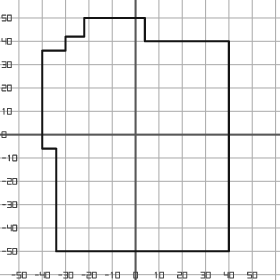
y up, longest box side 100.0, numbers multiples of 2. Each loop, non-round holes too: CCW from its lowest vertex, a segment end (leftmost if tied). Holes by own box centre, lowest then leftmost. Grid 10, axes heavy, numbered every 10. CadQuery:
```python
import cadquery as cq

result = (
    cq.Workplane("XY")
    .moveTo(-34.0, -50.0)
    .lineTo(40.0, -50.0)
    .lineTo(40.0, 40.0)
    .lineTo(4.0, 40.0)
    .lineTo(4.0, 50.0)
    .lineTo(-22.0, 50.0)
    .lineTo(-22.0, 42.0)
    .lineTo(-30.0, 42.0)
    .lineTo(-30.0, 36.0)
    .lineTo(-40.0, 36.0)
    .lineTo(-40.0, -6.0)
    .lineTo(-34.0, -6.0)
    .close()
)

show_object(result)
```